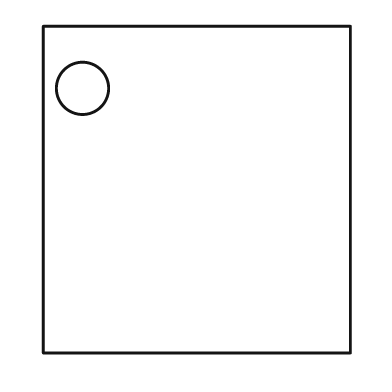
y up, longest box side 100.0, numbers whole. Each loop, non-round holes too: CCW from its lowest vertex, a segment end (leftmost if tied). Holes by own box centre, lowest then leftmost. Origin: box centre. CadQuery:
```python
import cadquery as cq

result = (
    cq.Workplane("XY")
    .moveTo(-47.0, -50.0)
    .lineTo(47.0, -50.0)
    .lineTo(47.0, 50.0)
    .lineTo(-47.0, 50.0)
    .close()
    .moveTo(-35.0, 31.0)
    .circle(8.0)
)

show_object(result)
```